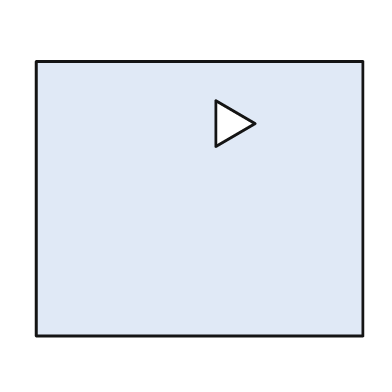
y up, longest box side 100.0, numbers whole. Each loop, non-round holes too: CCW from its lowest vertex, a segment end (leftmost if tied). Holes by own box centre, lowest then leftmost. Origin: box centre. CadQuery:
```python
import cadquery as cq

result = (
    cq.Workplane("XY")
    .moveTo(-50.0, -42.0)
    .lineTo(50.0, -42.0)
    .lineTo(50.0, 42.0)
    .lineTo(-50.0, 42.0)
    .close()
    .moveTo(5.0, 16.0)
    .lineTo(17.0, 23.0)
    .lineTo(5.0, 30.0)
    .close()
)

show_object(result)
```